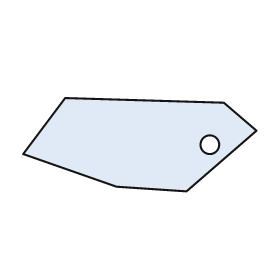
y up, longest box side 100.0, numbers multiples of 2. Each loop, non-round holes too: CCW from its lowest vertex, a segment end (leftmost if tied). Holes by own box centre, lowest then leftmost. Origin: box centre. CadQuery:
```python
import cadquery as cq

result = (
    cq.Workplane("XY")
    .moveTo(20.0, -20.0)
    .lineTo(50.0, 6.0)
    .lineTo(36.0, 18.0)
    .lineTo(-32.0, 20.0)
    .lineTo(-50.0, -4.0)
    .lineTo(-10.0, -18.0)
    .close()
    .moveTo(30.0, 0.0)
    .circle(4.0)
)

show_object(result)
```